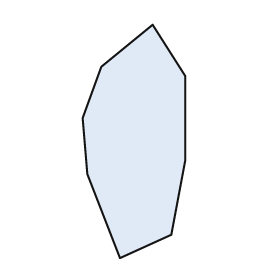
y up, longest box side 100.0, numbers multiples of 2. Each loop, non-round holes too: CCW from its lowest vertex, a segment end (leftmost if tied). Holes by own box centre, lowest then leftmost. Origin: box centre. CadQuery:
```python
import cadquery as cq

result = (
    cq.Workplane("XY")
    .moveTo(-6.0, -50.0)
    .lineTo(16.0, -40.0)
    .lineTo(22.0, -8.0)
    .lineTo(22.0, 28.0)
    .lineTo(8.0, 50.0)
    .lineTo(-14.0, 32.0)
    .lineTo(-22.0, 10.0)
    .lineTo(-20.0, -14.0)
    .close()
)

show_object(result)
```